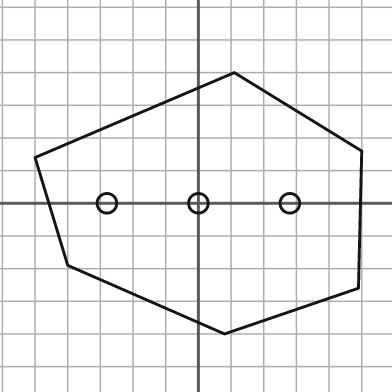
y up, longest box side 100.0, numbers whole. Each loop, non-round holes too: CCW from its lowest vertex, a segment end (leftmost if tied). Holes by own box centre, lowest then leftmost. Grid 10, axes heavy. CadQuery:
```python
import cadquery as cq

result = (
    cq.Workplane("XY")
    .moveTo(8.0, -40.0)
    .lineTo(49.0, -26.0)
    .lineTo(50.0, 16.0)
    .lineTo(11.0, 40.0)
    .lineTo(-50.0, 14.0)
    .lineTo(-40.0, -19.0)
    .close()
    .moveTo(-28.0, 0.0)
    .circle(3.0)
    .moveTo(0.0, 0.0)
    .circle(3.0)
    .moveTo(28.0, 0.0)
    .circle(3.0)
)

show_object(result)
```